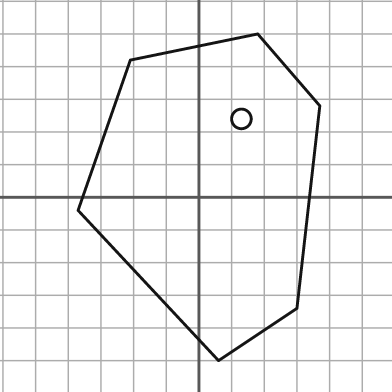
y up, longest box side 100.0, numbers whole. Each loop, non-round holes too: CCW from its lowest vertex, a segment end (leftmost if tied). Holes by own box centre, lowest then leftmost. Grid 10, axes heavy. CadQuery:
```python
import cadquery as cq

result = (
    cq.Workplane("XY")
    .moveTo(6.0, -50.0)
    .lineTo(30.0, -34.0)
    .lineTo(37.0, 28.0)
    .lineTo(18.0, 50.0)
    .lineTo(-21.0, 42.0)
    .lineTo(-37.0, -4.0)
    .close()
    .moveTo(13.0, 24.0)
    .circle(3.0)
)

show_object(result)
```